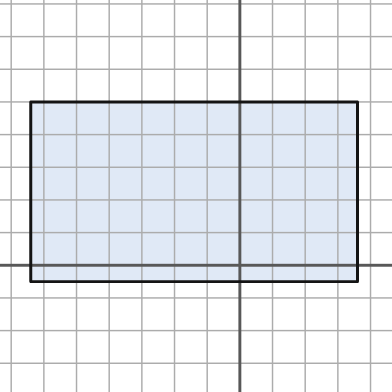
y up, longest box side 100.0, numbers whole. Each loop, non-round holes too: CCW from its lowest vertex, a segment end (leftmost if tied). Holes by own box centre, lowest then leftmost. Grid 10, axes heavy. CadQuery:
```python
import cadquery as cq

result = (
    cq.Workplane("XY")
    .moveTo(-64.0, -5.0)
    .lineTo(36.0, -5.0)
    .lineTo(36.0, 50.0)
    .lineTo(-64.0, 50.0)
    .close()
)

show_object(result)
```